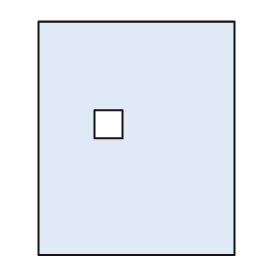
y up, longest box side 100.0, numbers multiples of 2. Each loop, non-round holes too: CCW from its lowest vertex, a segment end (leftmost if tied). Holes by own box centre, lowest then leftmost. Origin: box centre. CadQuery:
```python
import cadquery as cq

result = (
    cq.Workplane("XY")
    .moveTo(-42.0, -50.0)
    .lineTo(42.0, -50.0)
    .lineTo(42.0, 50.0)
    .lineTo(-42.0, 50.0)
    .close()
    .moveTo(-18.0, 0.0)
    .lineTo(-6.0, 0.0)
    .lineTo(-6.0, 12.0)
    .lineTo(-18.0, 12.0)
    .close()
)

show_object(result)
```